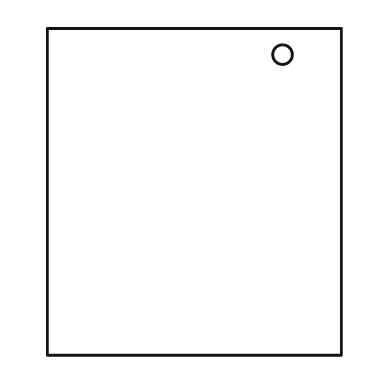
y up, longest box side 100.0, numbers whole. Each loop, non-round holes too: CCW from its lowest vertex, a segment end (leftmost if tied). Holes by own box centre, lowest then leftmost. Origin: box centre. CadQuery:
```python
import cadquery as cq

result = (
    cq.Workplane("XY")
    .moveTo(-45.0, -50.0)
    .lineTo(45.0, -50.0)
    .lineTo(45.0, 50.0)
    .lineTo(-45.0, 50.0)
    .close()
    .moveTo(27.0, 42.0)
    .circle(3.0)
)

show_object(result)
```